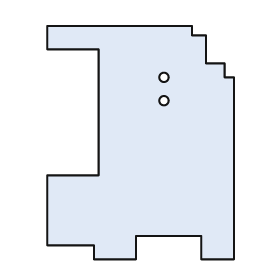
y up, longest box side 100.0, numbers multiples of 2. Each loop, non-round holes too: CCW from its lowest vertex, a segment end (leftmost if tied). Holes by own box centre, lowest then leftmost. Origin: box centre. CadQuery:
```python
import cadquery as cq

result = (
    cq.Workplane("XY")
    .moveTo(-20.0, -50.0)
    .lineTo(-2.0, -50.0)
    .lineTo(-2.0, -40.0)
    .lineTo(26.0, -40.0)
    .lineTo(26.0, -50.0)
    .lineTo(40.0, -50.0)
    .lineTo(40.0, 28.0)
    .lineTo(36.0, 28.0)
    .lineTo(36.0, 34.0)
    .lineTo(28.0, 34.0)
    .lineTo(28.0, 46.0)
    .lineTo(22.0, 46.0)
    .lineTo(22.0, 50.0)
    .lineTo(-40.0, 50.0)
    .lineTo(-40.0, 40.0)
    .lineTo(-18.0, 40.0)
    .lineTo(-18.0, -14.0)
    .lineTo(-40.0, -14.0)
    .lineTo(-40.0, -44.0)
    .lineTo(-20.0, -44.0)
    .close()
    .moveTo(10.0, 18.0)
    .circle(2.0)
    .moveTo(10.0, 28.0)
    .circle(2.0)
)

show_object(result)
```